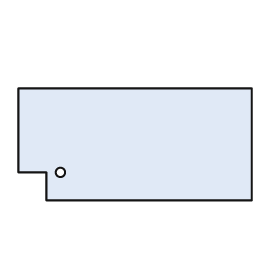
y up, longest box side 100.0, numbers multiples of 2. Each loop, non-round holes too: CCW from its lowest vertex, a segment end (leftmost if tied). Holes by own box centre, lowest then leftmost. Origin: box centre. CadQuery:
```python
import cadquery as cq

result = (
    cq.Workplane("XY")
    .moveTo(-38.0, -24.0)
    .lineTo(50.0, -24.0)
    .lineTo(50.0, 24.0)
    .lineTo(-50.0, 24.0)
    .lineTo(-50.0, -12.0)
    .lineTo(-38.0, -12.0)
    .close()
    .moveTo(-32.0, -12.0)
    .circle(2.0)
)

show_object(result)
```